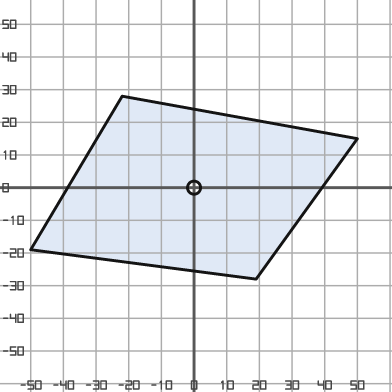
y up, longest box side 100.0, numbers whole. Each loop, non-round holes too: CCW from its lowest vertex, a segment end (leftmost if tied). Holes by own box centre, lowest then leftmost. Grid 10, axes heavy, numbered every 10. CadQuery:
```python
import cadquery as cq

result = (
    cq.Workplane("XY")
    .moveTo(19.0, -28.0)
    .lineTo(50.0, 15.0)
    .lineTo(-22.0, 28.0)
    .lineTo(-50.0, -19.0)
    .close()
    .moveTo(0.0, 0.0)
    .circle(2.0)
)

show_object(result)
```